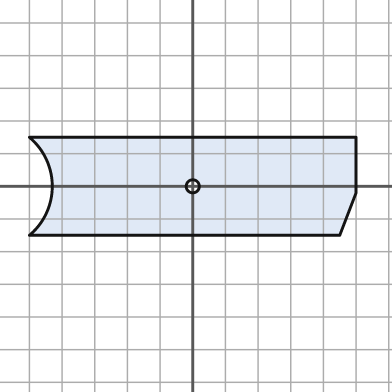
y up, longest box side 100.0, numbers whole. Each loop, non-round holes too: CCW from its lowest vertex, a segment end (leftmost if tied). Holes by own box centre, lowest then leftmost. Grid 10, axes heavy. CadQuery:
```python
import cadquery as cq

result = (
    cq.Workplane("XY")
    .moveTo(-50.0, -15.0)
    .lineTo(45.0, -15.0)
    .lineTo(50.0, -2.0)
    .lineTo(50.0, 15.0)
    .lineTo(-50.0, 15.0)
    .threePointArc((-43.0, 0.0), (-50.0, -15.0))
    .close()
    .moveTo(0.0, 0.0)
    .circle(2.0)
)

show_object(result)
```